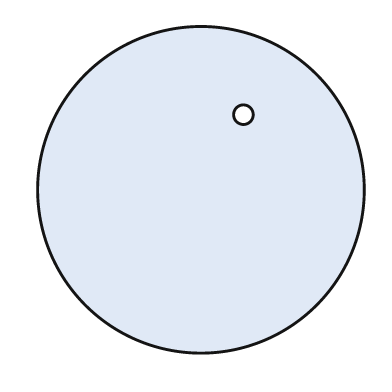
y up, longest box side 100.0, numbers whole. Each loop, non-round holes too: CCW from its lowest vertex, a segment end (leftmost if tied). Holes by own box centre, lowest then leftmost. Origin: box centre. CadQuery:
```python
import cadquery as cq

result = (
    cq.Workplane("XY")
    .moveTo(0.0, 0.0)
    .circle(50.0)
    .moveTo(13.0, 23.0)
    .circle(3.0)
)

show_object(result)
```